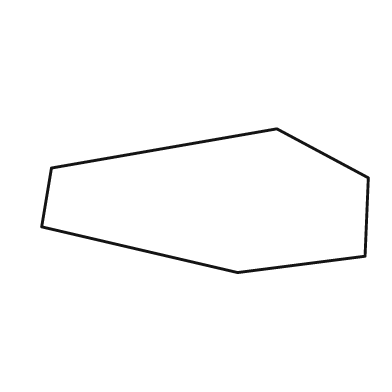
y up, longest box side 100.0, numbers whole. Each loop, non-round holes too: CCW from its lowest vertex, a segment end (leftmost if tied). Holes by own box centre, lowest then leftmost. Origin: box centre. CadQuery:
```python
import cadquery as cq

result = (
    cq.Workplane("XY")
    .moveTo(10.0, -22.0)
    .lineTo(49.0, -17.0)
    .lineTo(50.0, 7.0)
    .lineTo(22.0, 22.0)
    .lineTo(-47.0, 10.0)
    .lineTo(-50.0, -8.0)
    .close()
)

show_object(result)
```